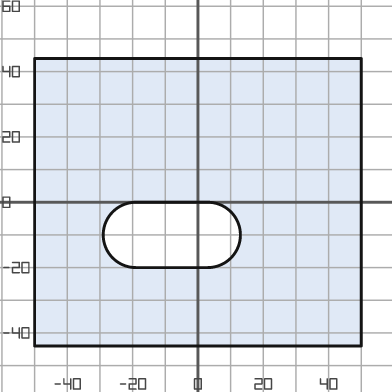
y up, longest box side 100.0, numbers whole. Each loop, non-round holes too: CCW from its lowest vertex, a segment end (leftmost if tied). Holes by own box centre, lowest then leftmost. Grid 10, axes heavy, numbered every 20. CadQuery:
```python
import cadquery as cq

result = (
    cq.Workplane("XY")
    .moveTo(-50.0, -44.0)
    .lineTo(50.0, -44.0)
    .lineTo(50.0, 44.0)
    .lineTo(-50.0, 44.0)
    .close()
    .moveTo(-19.0, -20.0)
    .lineTo(3.0, -20.0)
    .threePointArc((13.0, -10.0), (3.0, 0.0))
    .lineTo(-19.0, 0.0)
    .threePointArc((-29.0, -10.0), (-19.0, -20.0))
    .close()
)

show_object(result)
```